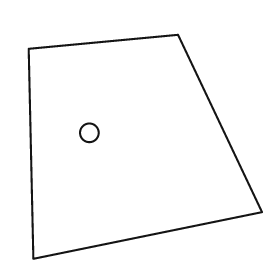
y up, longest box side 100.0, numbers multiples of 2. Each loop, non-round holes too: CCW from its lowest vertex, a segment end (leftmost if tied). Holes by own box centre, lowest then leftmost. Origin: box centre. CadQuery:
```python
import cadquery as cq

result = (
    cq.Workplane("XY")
    .moveTo(-48.0, -48.0)
    .lineTo(50.0, -28.0)
    .lineTo(14.0, 48.0)
    .lineTo(-50.0, 42.0)
    .close()
    .moveTo(-24.0, 6.0)
    .circle(4.0)
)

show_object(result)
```